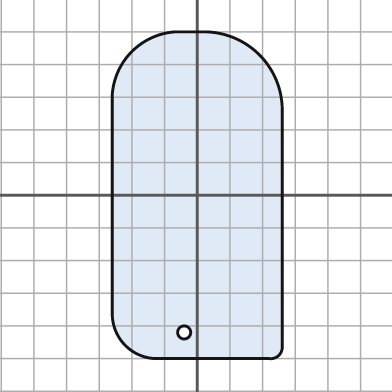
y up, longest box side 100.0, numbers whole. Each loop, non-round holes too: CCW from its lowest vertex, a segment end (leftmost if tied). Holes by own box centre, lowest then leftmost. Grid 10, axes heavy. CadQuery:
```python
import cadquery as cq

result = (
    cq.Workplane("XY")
    .moveTo(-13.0, -50.0)
    .lineTo(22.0, -50.0)
    .threePointArc((25.0, -49.0), (26.0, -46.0))
    .lineTo(26.0, 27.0)
    .threePointArc((19.0, 43.0), (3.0, 50.0))
    .lineTo(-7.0, 50.0)
    .threePointArc((-20.0, 44.0), (-26.0, 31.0))
    .lineTo(-26.0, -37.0)
    .threePointArc((-22.0, -46.0), (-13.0, -50.0))
    .close()
    .moveTo(-4.0, -42.0)
    .circle(2.0)
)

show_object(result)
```